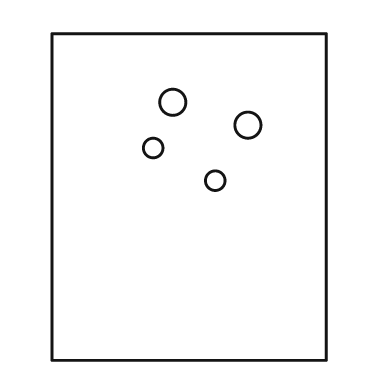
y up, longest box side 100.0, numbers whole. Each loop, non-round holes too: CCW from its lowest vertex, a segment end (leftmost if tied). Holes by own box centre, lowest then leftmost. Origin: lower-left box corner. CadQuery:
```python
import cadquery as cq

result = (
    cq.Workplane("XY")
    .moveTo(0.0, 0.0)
    .lineTo(84.0, 0.0)
    .lineTo(84.0, 100.0)
    .lineTo(0.0, 100.0)
    .close()
    .moveTo(50.0, 55.0)
    .circle(3.0)
    .moveTo(31.0, 65.0)
    .circle(3.0)
    .moveTo(60.0, 72.0)
    .circle(4.0)
    .moveTo(37.0, 79.0)
    .circle(4.0)
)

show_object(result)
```